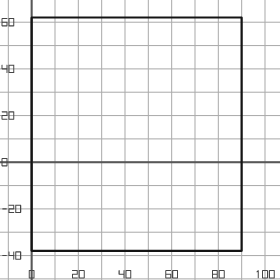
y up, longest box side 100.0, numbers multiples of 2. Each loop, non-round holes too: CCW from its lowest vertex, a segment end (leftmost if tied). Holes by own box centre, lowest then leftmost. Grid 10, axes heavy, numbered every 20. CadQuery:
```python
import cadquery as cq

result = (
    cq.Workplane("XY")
    .moveTo(0.0, -38.0)
    .lineTo(90.0, -38.0)
    .lineTo(90.0, 62.0)
    .lineTo(0.0, 62.0)
    .close()
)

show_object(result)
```